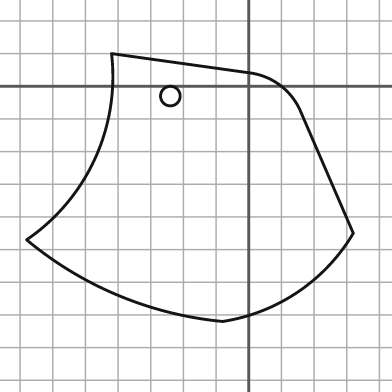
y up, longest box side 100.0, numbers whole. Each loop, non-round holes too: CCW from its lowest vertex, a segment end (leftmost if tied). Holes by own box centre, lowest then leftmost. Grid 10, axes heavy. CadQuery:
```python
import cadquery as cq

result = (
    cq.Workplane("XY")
    .moveTo(-8.0, -72.0)
    .threePointArc((15.0, -63.0), (32.0, -45.0))
    .lineTo(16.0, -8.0)
    .threePointArc((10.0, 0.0), (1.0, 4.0))
    .lineTo(-42.0, 10.0)
    .threePointArc((-47.0, -22.0), (-68.0, -47.0))
    .threePointArc((-40.0, -64.0), (-8.0, -72.0))
    .close()
    .moveTo(-24.0, -3.0)
    .circle(3.0)
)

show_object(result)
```